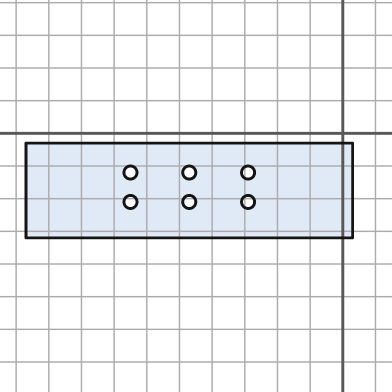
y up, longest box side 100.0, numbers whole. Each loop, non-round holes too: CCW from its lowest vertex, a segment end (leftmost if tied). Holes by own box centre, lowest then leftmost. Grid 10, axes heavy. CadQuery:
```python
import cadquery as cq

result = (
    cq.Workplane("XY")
    .moveTo(-97.0, -32.0)
    .lineTo(3.0, -32.0)
    .lineTo(3.0, -3.0)
    .lineTo(-97.0, -3.0)
    .close()
    .moveTo(-65.0, -21.0)
    .circle(2.0)
    .moveTo(-47.0, -21.0)
    .circle(2.0)
    .moveTo(-29.0, -21.0)
    .circle(2.0)
    .moveTo(-65.0, -12.0)
    .circle(2.0)
    .moveTo(-47.0, -12.0)
    .circle(2.0)
    .moveTo(-29.0, -12.0)
    .circle(2.0)
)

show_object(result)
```